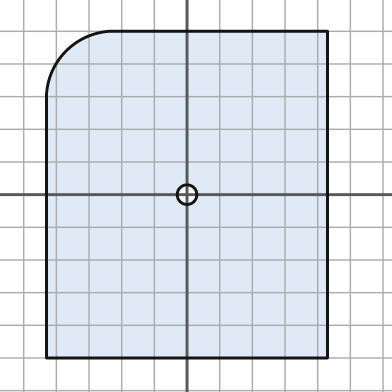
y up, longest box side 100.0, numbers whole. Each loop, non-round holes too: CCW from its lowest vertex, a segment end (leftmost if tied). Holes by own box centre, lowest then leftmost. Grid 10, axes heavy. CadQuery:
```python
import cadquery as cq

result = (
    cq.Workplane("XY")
    .moveTo(-43.0, -50.0)
    .lineTo(43.0, -50.0)
    .lineTo(43.0, 50.0)
    .lineTo(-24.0, 50.0)
    .threePointArc((-37.0, 44.0), (-43.0, 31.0))
    .close()
    .moveTo(0.0, 0.0)
    .circle(3.0)
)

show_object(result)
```